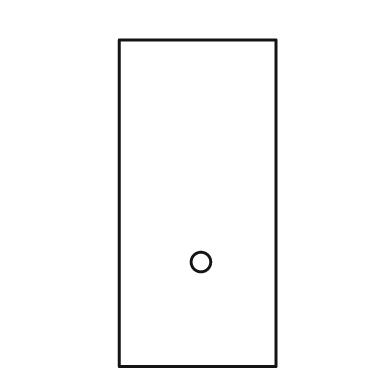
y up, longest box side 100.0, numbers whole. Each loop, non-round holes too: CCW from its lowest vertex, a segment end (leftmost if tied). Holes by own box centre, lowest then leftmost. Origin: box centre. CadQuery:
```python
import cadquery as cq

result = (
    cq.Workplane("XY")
    .moveTo(-24.0, -50.0)
    .lineTo(24.0, -50.0)
    .lineTo(24.0, 50.0)
    .lineTo(-24.0, 50.0)
    .close()
    .moveTo(1.0, -18.0)
    .circle(3.0)
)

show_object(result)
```